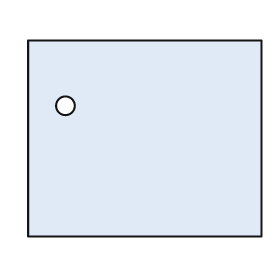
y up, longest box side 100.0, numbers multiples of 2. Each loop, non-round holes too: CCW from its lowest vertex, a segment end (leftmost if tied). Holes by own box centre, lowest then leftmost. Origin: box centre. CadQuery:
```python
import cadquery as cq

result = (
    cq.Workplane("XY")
    .moveTo(-50.0, -42.0)
    .lineTo(50.0, -42.0)
    .lineTo(50.0, 42.0)
    .lineTo(-50.0, 42.0)
    .close()
    .moveTo(-34.0, 14.0)
    .circle(4.0)
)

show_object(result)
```